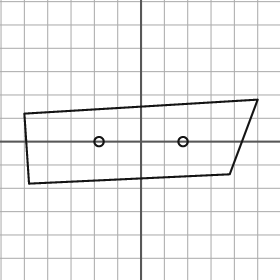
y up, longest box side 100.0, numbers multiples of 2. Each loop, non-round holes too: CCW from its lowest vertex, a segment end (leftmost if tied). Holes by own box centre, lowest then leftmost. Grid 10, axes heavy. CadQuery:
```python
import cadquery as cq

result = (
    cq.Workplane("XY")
    .moveTo(-48.0, -18.0)
    .lineTo(38.0, -14.0)
    .lineTo(50.0, 18.0)
    .lineTo(-50.0, 12.0)
    .close()
    .moveTo(-18.0, 0.0)
    .circle(2.0)
    .moveTo(18.0, 0.0)
    .circle(2.0)
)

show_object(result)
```